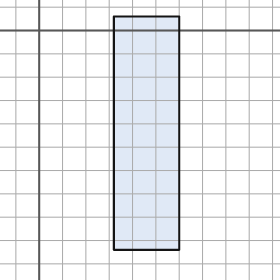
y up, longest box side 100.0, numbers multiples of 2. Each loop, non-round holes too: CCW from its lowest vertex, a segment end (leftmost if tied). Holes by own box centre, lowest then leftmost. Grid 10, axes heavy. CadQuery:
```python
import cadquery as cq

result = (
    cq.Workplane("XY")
    .moveTo(32.0, -94.0)
    .lineTo(60.0, -94.0)
    .lineTo(60.0, 6.0)
    .lineTo(32.0, 6.0)
    .close()
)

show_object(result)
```